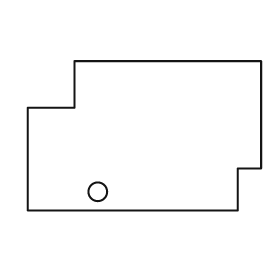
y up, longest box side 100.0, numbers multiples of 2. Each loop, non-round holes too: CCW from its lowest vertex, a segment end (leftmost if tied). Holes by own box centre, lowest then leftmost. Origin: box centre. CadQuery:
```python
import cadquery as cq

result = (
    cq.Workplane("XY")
    .moveTo(-50.0, -32.0)
    .lineTo(40.0, -32.0)
    .lineTo(40.0, -14.0)
    .lineTo(50.0, -14.0)
    .lineTo(50.0, 32.0)
    .lineTo(-30.0, 32.0)
    .lineTo(-30.0, 12.0)
    .lineTo(-50.0, 12.0)
    .close()
    .moveTo(-20.0, -24.0)
    .circle(4.0)
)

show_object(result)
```